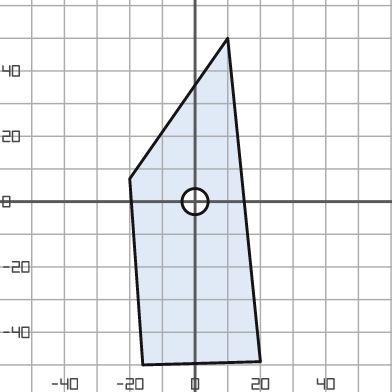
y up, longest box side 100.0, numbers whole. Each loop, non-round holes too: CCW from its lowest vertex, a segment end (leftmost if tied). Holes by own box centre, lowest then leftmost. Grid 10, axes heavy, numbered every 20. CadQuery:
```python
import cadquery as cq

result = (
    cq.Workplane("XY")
    .moveTo(-16.0, -50.0)
    .lineTo(20.0, -49.0)
    .lineTo(10.0, 50.0)
    .lineTo(-20.0, 7.0)
    .close()
    .moveTo(0.0, 0.0)
    .circle(4.0)
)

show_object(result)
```